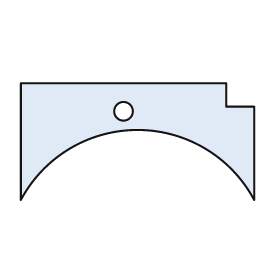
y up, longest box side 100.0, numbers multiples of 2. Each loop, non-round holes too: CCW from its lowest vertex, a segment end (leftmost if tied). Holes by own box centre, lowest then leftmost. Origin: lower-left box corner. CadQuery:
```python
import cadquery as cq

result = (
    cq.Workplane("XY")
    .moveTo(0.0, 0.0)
    .threePointArc((50.0, 30.0), (100.0, 0.0))
    .lineTo(100.0, 40.0)
    .lineTo(88.0, 40.0)
    .lineTo(88.0, 50.0)
    .lineTo(0.0, 50.0)
    .close()
    .moveTo(44.0, 38.0)
    .circle(4.0)
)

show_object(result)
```